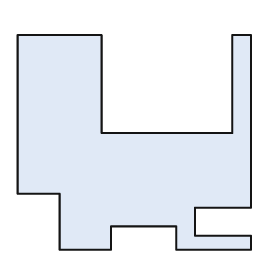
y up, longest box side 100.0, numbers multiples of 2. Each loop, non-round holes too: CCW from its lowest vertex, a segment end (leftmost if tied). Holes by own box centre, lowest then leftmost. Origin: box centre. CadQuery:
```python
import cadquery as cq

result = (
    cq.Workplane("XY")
    .moveTo(-32.0, -46.0)
    .lineTo(-10.0, -46.0)
    .lineTo(-10.0, -36.0)
    .lineTo(18.0, -36.0)
    .lineTo(18.0, -46.0)
    .lineTo(50.0, -46.0)
    .lineTo(50.0, -40.0)
    .lineTo(26.0, -40.0)
    .lineTo(26.0, -28.0)
    .lineTo(50.0, -28.0)
    .lineTo(50.0, 46.0)
    .lineTo(42.0, 46.0)
    .lineTo(42.0, 4.0)
    .lineTo(-14.0, 4.0)
    .lineTo(-14.0, 46.0)
    .lineTo(-50.0, 46.0)
    .lineTo(-50.0, -22.0)
    .lineTo(-32.0, -22.0)
    .close()
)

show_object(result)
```